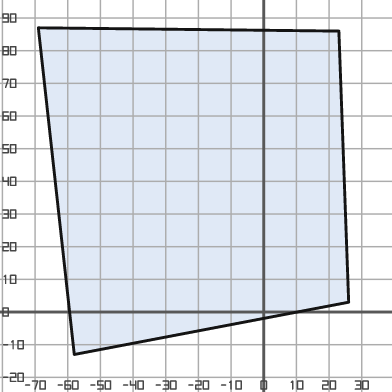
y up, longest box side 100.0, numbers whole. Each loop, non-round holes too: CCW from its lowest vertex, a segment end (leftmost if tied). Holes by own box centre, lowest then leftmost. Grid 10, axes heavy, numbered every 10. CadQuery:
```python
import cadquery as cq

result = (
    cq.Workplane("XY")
    .moveTo(-58.0, -13.0)
    .lineTo(26.0, 3.0)
    .lineTo(23.0, 86.0)
    .lineTo(-69.0, 87.0)
    .close()
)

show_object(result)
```